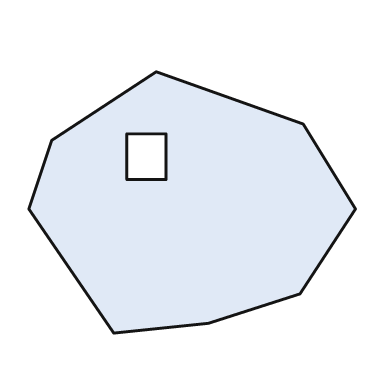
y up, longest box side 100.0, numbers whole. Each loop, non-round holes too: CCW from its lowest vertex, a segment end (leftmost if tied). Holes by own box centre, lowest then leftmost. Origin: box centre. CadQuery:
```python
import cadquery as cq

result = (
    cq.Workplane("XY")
    .moveTo(-24.0, -40.0)
    .lineTo(5.0, -37.0)
    .lineTo(33.0, -28.0)
    .lineTo(50.0, -2.0)
    .lineTo(34.0, 24.0)
    .lineTo(-11.0, 40.0)
    .lineTo(-43.0, 19.0)
    .lineTo(-50.0, -2.0)
    .close()
    .moveTo(-20.0, 7.0)
    .lineTo(-8.0, 7.0)
    .lineTo(-8.0, 21.0)
    .lineTo(-20.0, 21.0)
    .close()
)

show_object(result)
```